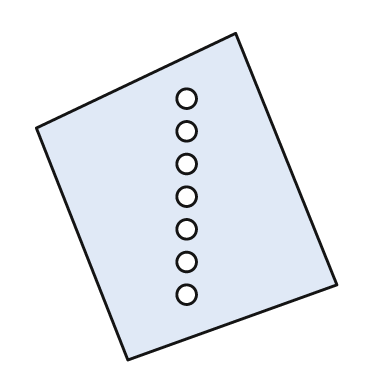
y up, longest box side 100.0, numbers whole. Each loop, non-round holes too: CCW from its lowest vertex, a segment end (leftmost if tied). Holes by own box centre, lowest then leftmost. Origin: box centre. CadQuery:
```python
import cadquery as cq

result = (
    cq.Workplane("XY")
    .moveTo(-18.0, -50.0)
    .lineTo(46.0, -27.0)
    .lineTo(15.0, 50.0)
    .lineTo(-46.0, 21.0)
    .close()
    .moveTo(0.0, -30.0)
    .circle(3.0)
    .moveTo(0.0, -20.0)
    .circle(3.0)
    .moveTo(0.0, -10.0)
    .circle(3.0)
    .moveTo(0.0, 0.0)
    .circle(3.0)
    .moveTo(0.0, 10.0)
    .circle(3.0)
    .moveTo(0.0, 20.0)
    .circle(3.0)
    .moveTo(0.0, 30.0)
    .circle(3.0)
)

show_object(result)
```